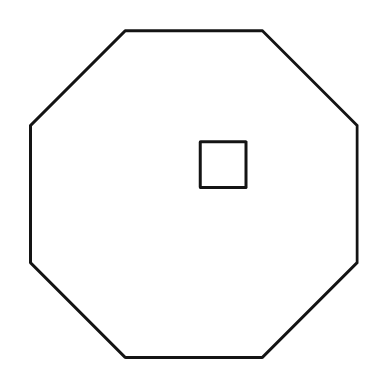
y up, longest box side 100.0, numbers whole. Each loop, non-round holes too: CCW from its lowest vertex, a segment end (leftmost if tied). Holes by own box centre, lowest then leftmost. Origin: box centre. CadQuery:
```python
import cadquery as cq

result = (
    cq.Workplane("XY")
    .moveTo(-21.0, -50.0)
    .lineTo(21.0, -50.0)
    .lineTo(50.0, -21.0)
    .lineTo(50.0, 21.0)
    .lineTo(21.0, 50.0)
    .lineTo(-21.0, 50.0)
    .lineTo(-50.0, 21.0)
    .lineTo(-50.0, -21.0)
    .close()
    .moveTo(2.0, 2.0)
    .lineTo(16.0, 2.0)
    .lineTo(16.0, 16.0)
    .lineTo(2.0, 16.0)
    .close()
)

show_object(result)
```